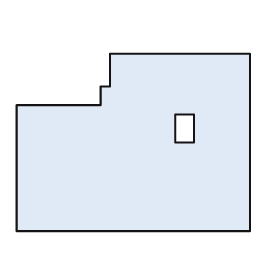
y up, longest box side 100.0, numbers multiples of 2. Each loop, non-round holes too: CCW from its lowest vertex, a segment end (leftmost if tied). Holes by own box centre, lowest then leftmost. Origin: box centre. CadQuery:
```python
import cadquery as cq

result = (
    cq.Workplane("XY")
    .moveTo(-50.0, -38.0)
    .lineTo(50.0, -38.0)
    .lineTo(50.0, 38.0)
    .lineTo(-10.0, 38.0)
    .lineTo(-10.0, 24.0)
    .lineTo(-14.0, 24.0)
    .lineTo(-14.0, 16.0)
    .lineTo(-50.0, 16.0)
    .close()
    .moveTo(18.0, 0.0)
    .lineTo(26.0, 0.0)
    .lineTo(26.0, 12.0)
    .lineTo(18.0, 12.0)
    .close()
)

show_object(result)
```